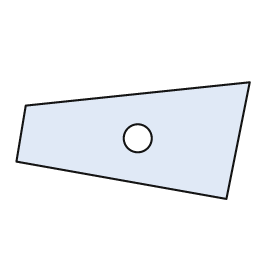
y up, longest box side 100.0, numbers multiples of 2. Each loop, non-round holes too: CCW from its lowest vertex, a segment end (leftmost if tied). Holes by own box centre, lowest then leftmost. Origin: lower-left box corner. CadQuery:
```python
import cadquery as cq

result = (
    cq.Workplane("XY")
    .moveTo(90.0, 0.0)
    .lineTo(100.0, 50.0)
    .lineTo(4.0, 40.0)
    .lineTo(0.0, 16.0)
    .close()
    .moveTo(52.0, 26.0)
    .circle(6.0)
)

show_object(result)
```